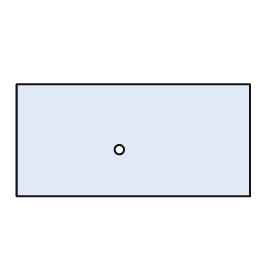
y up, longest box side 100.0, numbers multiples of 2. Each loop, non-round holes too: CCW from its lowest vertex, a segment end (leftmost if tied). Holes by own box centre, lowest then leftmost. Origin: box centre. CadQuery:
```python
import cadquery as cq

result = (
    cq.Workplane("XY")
    .moveTo(-50.0, -24.0)
    .lineTo(50.0, -24.0)
    .lineTo(50.0, 24.0)
    .lineTo(-50.0, 24.0)
    .close()
    .moveTo(-6.0, -4.0)
    .circle(2.0)
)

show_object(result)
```